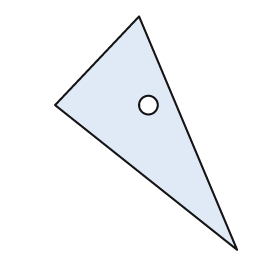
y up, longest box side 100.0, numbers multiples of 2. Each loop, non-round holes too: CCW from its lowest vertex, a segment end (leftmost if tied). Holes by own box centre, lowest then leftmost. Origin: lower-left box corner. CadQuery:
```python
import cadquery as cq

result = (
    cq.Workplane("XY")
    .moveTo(78.0, 0.0)
    .lineTo(36.0, 100.0)
    .lineTo(0.0, 62.0)
    .close()
    .moveTo(40.0, 62.0)
    .circle(4.0)
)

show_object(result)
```